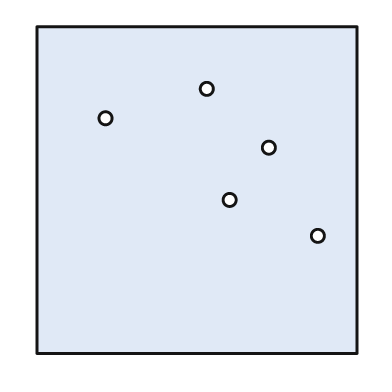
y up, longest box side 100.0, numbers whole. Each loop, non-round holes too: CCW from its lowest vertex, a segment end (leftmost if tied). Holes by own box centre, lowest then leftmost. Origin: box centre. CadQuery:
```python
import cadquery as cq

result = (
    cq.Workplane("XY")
    .moveTo(-49.0, -50.0)
    .lineTo(49.0, -50.0)
    .lineTo(49.0, 50.0)
    .lineTo(-49.0, 50.0)
    .close()
    .moveTo(37.0, -14.0)
    .circle(2.0)
    .moveTo(10.0, -3.0)
    .circle(2.0)
    .moveTo(22.0, 13.0)
    .circle(2.0)
    .moveTo(-28.0, 22.0)
    .circle(2.0)
    .moveTo(3.0, 31.0)
    .circle(2.0)
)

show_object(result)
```